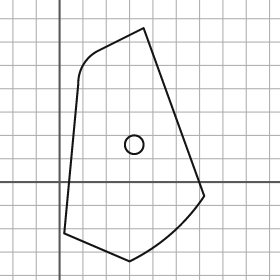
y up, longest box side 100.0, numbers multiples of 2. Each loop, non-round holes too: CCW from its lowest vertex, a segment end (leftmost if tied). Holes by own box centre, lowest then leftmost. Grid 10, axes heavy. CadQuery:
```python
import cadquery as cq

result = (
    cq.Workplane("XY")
    .moveTo(30.0, -34.0)
    .threePointArc((48.0, -22.0), (62.0, -6.0))
    .lineTo(36.0, 66.0)
    .lineTo(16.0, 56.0)
    .threePointArc((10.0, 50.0), (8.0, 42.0))
    .lineTo(2.0, -22.0)
    .close()
    .moveTo(32.0, 16.0)
    .circle(4.0)
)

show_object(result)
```